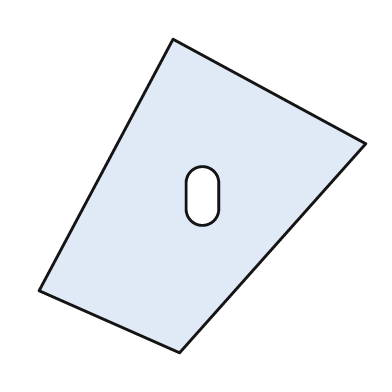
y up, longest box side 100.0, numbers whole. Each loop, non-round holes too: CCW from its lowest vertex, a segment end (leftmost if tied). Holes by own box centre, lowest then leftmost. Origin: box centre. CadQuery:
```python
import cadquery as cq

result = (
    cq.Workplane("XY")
    .moveTo(-7.0, -48.0)
    .lineTo(50.0, 16.0)
    .lineTo(-9.0, 48.0)
    .lineTo(-50.0, -29.0)
    .close()
    .moveTo(-5.0, -4.0)
    .threePointArc((0.0, -9.0), (5.0, -4.0))
    .lineTo(5.0, 4.0)
    .threePointArc((0.0, 9.0), (-5.0, 4.0))
    .close()
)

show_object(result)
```